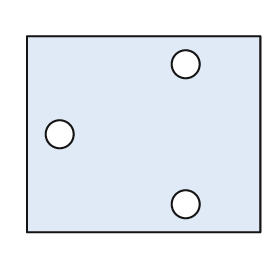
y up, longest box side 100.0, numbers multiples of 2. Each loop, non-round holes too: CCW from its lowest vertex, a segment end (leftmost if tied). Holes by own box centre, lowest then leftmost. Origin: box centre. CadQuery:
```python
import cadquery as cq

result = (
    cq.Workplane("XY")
    .moveTo(-50.0, -42.0)
    .lineTo(50.0, -42.0)
    .lineTo(50.0, 42.0)
    .lineTo(-50.0, 42.0)
    .close()
    .moveTo(18.0, -30.0)
    .circle(6.0)
    .moveTo(-36.0, 0.0)
    .circle(6.0)
    .moveTo(18.0, 30.0)
    .circle(6.0)
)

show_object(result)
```